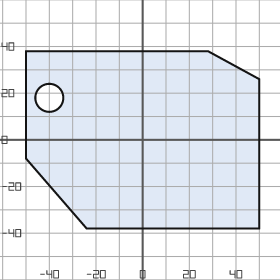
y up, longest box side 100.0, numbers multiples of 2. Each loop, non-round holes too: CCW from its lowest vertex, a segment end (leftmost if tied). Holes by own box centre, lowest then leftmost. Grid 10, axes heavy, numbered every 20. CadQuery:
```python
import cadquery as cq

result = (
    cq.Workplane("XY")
    .moveTo(-24.0, -38.0)
    .lineTo(50.0, -38.0)
    .lineTo(50.0, 26.0)
    .lineTo(28.0, 38.0)
    .lineTo(-50.0, 38.0)
    .lineTo(-50.0, -8.0)
    .close()
    .moveTo(-40.0, 18.0)
    .circle(6.0)
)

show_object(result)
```